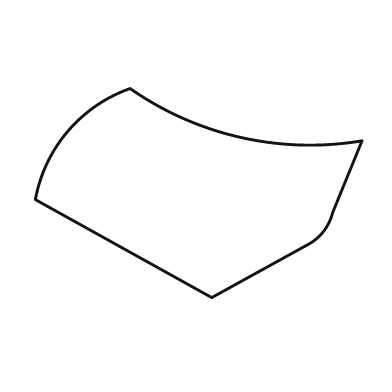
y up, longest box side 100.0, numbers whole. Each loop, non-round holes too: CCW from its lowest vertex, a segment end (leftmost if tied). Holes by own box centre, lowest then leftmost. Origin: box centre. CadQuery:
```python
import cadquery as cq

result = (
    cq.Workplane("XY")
    .moveTo(4.0, -32.0)
    .lineTo(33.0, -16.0)
    .threePointArc((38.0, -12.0), (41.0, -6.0))
    .lineTo(50.0, 16.0)
    .threePointArc((13.0, 17.0), (-21.0, 32.0))
    .threePointArc((-40.0, 19.0), (-50.0, -2.0))
    .close()
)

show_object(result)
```